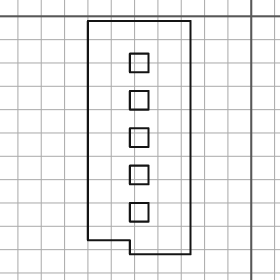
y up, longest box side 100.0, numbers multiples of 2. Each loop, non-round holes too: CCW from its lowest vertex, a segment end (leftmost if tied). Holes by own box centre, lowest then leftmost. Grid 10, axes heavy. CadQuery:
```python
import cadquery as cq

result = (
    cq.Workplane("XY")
    .moveTo(-52.0, -102.0)
    .lineTo(-26.0, -102.0)
    .lineTo(-26.0, -2.0)
    .lineTo(-70.0, -2.0)
    .lineTo(-70.0, -96.0)
    .lineTo(-52.0, -96.0)
    .close()
    .moveTo(-52.0, -88.0)
    .lineTo(-44.0, -88.0)
    .lineTo(-44.0, -80.0)
    .lineTo(-52.0, -80.0)
    .close()
    .moveTo(-52.0, -72.0)
    .lineTo(-44.0, -72.0)
    .lineTo(-44.0, -64.0)
    .lineTo(-52.0, -64.0)
    .close()
    .moveTo(-52.0, -56.0)
    .lineTo(-44.0, -56.0)
    .lineTo(-44.0, -48.0)
    .lineTo(-52.0, -48.0)
    .close()
    .moveTo(-52.0, -40.0)
    .lineTo(-44.0, -40.0)
    .lineTo(-44.0, -32.0)
    .lineTo(-52.0, -32.0)
    .close()
    .moveTo(-52.0, -24.0)
    .lineTo(-44.0, -24.0)
    .lineTo(-44.0, -16.0)
    .lineTo(-52.0, -16.0)
    .close()
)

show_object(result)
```